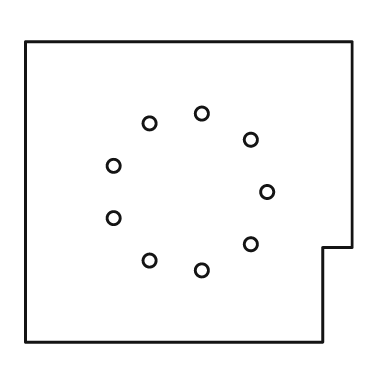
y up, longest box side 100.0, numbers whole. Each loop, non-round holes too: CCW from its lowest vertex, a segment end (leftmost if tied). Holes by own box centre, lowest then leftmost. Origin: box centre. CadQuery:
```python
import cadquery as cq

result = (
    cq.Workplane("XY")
    .moveTo(-50.0, -46.0)
    .lineTo(41.0, -46.0)
    .lineTo(41.0, -17.0)
    .lineTo(50.0, -17.0)
    .lineTo(50.0, 46.0)
    .lineTo(-50.0, 46.0)
    .close()
    .moveTo(4.0, -24.0)
    .circle(2.0)
    .moveTo(-12.0, -21.0)
    .circle(2.0)
    .moveTo(19.0, -16.0)
    .circle(2.0)
    .moveTo(-23.0, -8.0)
    .circle(2.0)
    .moveTo(24.0, 0.0)
    .circle(2.0)
    .moveTo(-23.0, 8.0)
    .circle(2.0)
    .moveTo(19.0, 16.0)
    .circle(2.0)
    .moveTo(-12.0, 21.0)
    .circle(2.0)
    .moveTo(4.0, 24.0)
    .circle(2.0)
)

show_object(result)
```